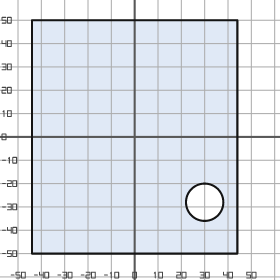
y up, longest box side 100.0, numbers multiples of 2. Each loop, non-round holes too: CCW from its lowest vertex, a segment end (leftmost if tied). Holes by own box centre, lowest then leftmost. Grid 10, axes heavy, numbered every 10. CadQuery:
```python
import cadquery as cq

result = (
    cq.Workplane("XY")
    .moveTo(-44.0, -50.0)
    .lineTo(44.0, -50.0)
    .lineTo(44.0, 50.0)
    .lineTo(-44.0, 50.0)
    .close()
    .moveTo(30.0, -28.0)
    .circle(8.0)
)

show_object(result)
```